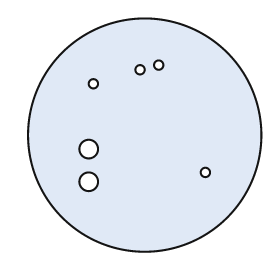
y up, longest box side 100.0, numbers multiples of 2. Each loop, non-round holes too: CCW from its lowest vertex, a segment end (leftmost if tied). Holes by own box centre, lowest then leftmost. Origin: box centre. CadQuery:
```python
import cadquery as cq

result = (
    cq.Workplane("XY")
    .moveTo(0.0, 0.0)
    .circle(50.0)
    .moveTo(-24.0, -20.0)
    .circle(4.0)
    .moveTo(26.0, -16.0)
    .circle(2.0)
    .moveTo(-24.0, -6.0)
    .circle(4.0)
    .moveTo(-22.0, 22.0)
    .circle(2.0)
    .moveTo(-2.0, 28.0)
    .circle(2.0)
    .moveTo(6.0, 30.0)
    .circle(2.0)
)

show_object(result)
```